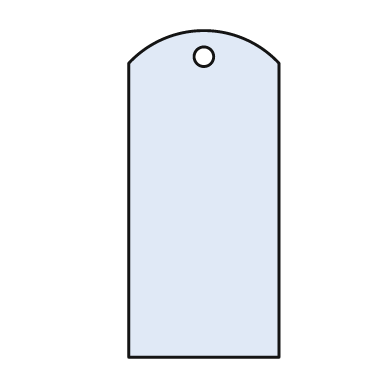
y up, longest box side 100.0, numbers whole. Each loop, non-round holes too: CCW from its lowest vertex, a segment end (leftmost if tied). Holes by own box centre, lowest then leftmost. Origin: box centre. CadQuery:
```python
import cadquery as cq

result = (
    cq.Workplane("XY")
    .moveTo(-23.0, -50.0)
    .lineTo(23.0, -50.0)
    .lineTo(23.0, 40.0)
    .threePointArc((0.0, 50.0), (-23.0, 40.0))
    .close()
    .moveTo(0.0, 42.0)
    .circle(3.0)
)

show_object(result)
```